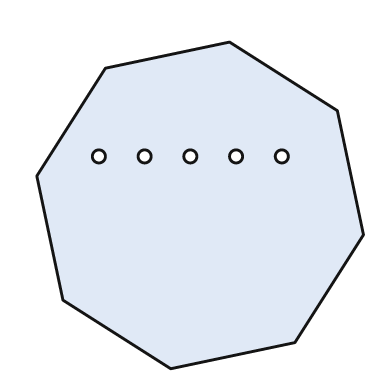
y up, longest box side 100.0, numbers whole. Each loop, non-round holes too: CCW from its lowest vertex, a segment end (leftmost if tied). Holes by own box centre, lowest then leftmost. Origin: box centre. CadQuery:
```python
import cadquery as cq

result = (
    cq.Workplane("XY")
    .moveTo(-9.0, -50.0)
    .lineTo(29.0, -42.0)
    .lineTo(50.0, -9.0)
    .lineTo(42.0, 29.0)
    .lineTo(9.0, 50.0)
    .lineTo(-29.0, 42.0)
    .lineTo(-50.0, 9.0)
    .lineTo(-42.0, -29.0)
    .close()
    .moveTo(-31.0, 15.0)
    .circle(2.0)
    .moveTo(-17.0, 15.0)
    .circle(2.0)
    .moveTo(-3.0, 15.0)
    .circle(2.0)
    .moveTo(11.0, 15.0)
    .circle(2.0)
    .moveTo(25.0, 15.0)
    .circle(2.0)
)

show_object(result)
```